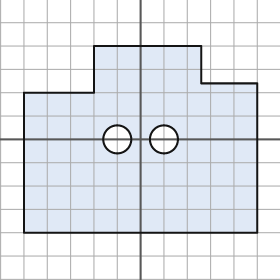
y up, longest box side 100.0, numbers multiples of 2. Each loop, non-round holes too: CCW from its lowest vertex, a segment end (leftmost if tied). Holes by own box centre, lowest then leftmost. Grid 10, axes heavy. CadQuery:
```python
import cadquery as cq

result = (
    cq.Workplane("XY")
    .moveTo(-50.0, -40.0)
    .lineTo(50.0, -40.0)
    .lineTo(50.0, 24.0)
    .lineTo(26.0, 24.0)
    .lineTo(26.0, 40.0)
    .lineTo(-20.0, 40.0)
    .lineTo(-20.0, 20.0)
    .lineTo(-50.0, 20.0)
    .close()
    .moveTo(-10.0, 0.0)
    .circle(6.0)
    .moveTo(10.0, 0.0)
    .circle(6.0)
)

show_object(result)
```